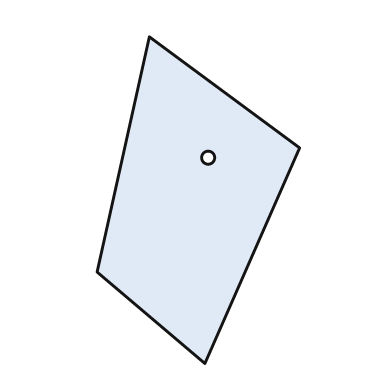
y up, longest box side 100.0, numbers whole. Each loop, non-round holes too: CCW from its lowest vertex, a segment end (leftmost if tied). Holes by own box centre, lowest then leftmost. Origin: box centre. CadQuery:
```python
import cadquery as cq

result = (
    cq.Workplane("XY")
    .moveTo(2.0, -50.0)
    .lineTo(31.0, 16.0)
    .lineTo(-15.0, 50.0)
    .lineTo(-31.0, -22.0)
    .close()
    .moveTo(3.0, 13.0)
    .circle(2.0)
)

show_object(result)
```